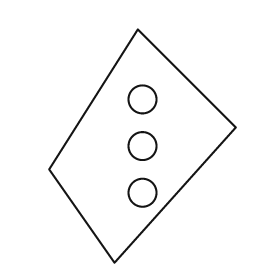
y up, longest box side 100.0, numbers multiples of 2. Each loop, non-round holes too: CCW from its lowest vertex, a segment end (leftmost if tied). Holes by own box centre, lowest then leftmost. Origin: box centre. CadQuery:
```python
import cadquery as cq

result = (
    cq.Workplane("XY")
    .moveTo(-12.0, -50.0)
    .lineTo(40.0, 8.0)
    .lineTo(-2.0, 50.0)
    .lineTo(-40.0, -10.0)
    .close()
    .moveTo(0.0, -20.0)
    .circle(6.0)
    .moveTo(0.0, 0.0)
    .circle(6.0)
    .moveTo(0.0, 20.0)
    .circle(6.0)
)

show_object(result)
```